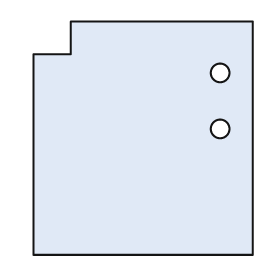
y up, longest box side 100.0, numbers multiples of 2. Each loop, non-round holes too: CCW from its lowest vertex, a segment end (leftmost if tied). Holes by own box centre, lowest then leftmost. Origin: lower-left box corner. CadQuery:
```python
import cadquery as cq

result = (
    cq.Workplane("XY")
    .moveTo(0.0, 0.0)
    .lineTo(94.0, 0.0)
    .lineTo(94.0, 100.0)
    .lineTo(16.0, 100.0)
    .lineTo(16.0, 86.0)
    .lineTo(0.0, 86.0)
    .close()
    .moveTo(80.0, 54.0)
    .circle(4.0)
    .moveTo(80.0, 78.0)
    .circle(4.0)
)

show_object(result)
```